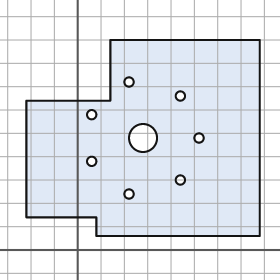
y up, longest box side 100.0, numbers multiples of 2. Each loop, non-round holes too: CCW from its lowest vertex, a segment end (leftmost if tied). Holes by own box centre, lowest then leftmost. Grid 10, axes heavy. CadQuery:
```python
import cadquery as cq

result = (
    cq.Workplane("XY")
    .moveTo(8.0, 6.0)
    .lineTo(78.0, 6.0)
    .lineTo(78.0, 90.0)
    .lineTo(14.0, 90.0)
    .lineTo(14.0, 64.0)
    .lineTo(-22.0, 64.0)
    .lineTo(-22.0, 14.0)
    .lineTo(8.0, 14.0)
    .close()
    .moveTo(22.0, 24.0)
    .circle(2.0)
    .moveTo(44.0, 30.0)
    .circle(2.0)
    .moveTo(6.0, 38.0)
    .circle(2.0)
    .moveTo(28.0, 48.0)
    .circle(6.0)
    .moveTo(52.0, 48.0)
    .circle(2.0)
    .moveTo(6.0, 58.0)
    .circle(2.0)
    .moveTo(44.0, 66.0)
    .circle(2.0)
    .moveTo(22.0, 72.0)
    .circle(2.0)
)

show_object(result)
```